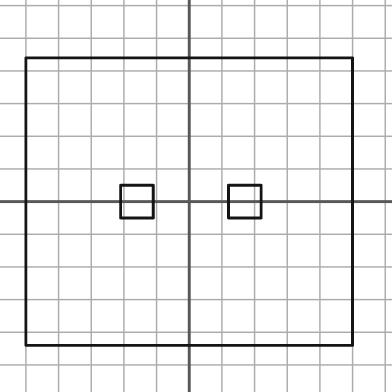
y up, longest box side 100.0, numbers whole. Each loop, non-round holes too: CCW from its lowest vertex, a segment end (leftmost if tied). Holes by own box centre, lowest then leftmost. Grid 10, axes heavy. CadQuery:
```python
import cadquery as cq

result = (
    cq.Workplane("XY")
    .moveTo(-50.0, -44.0)
    .lineTo(50.0, -44.0)
    .lineTo(50.0, 44.0)
    .lineTo(-50.0, 44.0)
    .close()
    .moveTo(-21.0, -5.0)
    .lineTo(-11.0, -5.0)
    .lineTo(-11.0, 5.0)
    .lineTo(-21.0, 5.0)
    .close()
    .moveTo(12.0, -5.0)
    .lineTo(22.0, -5.0)
    .lineTo(22.0, 5.0)
    .lineTo(12.0, 5.0)
    .close()
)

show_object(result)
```